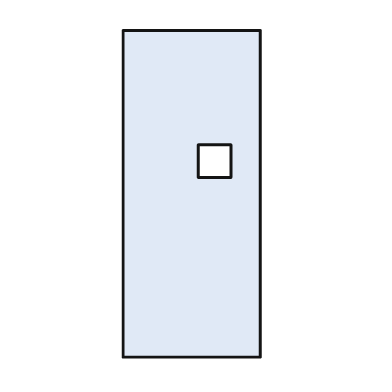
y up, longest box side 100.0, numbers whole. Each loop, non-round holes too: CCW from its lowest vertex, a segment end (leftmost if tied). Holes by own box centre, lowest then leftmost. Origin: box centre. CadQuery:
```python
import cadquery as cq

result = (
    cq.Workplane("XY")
    .moveTo(-21.0, -50.0)
    .lineTo(21.0, -50.0)
    .lineTo(21.0, 50.0)
    .lineTo(-21.0, 50.0)
    .close()
    .moveTo(2.0, 5.0)
    .lineTo(12.0, 5.0)
    .lineTo(12.0, 15.0)
    .lineTo(2.0, 15.0)
    .close()
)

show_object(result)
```